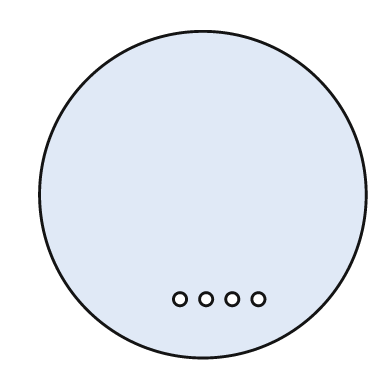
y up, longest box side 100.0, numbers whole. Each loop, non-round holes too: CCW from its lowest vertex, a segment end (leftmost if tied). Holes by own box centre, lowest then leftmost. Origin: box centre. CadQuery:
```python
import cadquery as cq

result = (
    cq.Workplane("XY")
    .moveTo(0.0, 0.0)
    .circle(50.0)
    .moveTo(-7.0, -32.0)
    .circle(2.0)
    .moveTo(1.0, -32.0)
    .circle(2.0)
    .moveTo(9.0, -32.0)
    .circle(2.0)
    .moveTo(17.0, -32.0)
    .circle(2.0)
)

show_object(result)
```